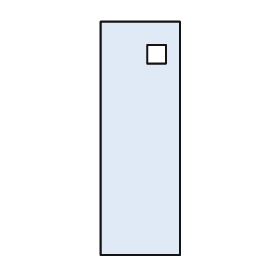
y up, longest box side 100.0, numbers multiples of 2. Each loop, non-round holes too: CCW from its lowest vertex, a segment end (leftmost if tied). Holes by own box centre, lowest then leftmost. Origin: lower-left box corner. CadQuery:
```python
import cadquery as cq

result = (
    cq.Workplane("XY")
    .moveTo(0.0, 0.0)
    .lineTo(34.0, 0.0)
    .lineTo(34.0, 100.0)
    .lineTo(0.0, 100.0)
    .close()
    .moveTo(20.0, 82.0)
    .lineTo(28.0, 82.0)
    .lineTo(28.0, 90.0)
    .lineTo(20.0, 90.0)
    .close()
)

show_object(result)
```